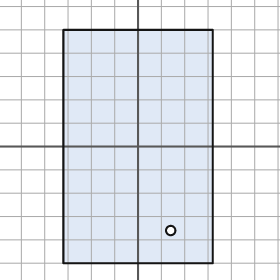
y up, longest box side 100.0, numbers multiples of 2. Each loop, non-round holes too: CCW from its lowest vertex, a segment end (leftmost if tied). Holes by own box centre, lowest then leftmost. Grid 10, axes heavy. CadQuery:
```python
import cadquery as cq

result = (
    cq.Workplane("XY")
    .moveTo(-32.0, -50.0)
    .lineTo(32.0, -50.0)
    .lineTo(32.0, 50.0)
    .lineTo(-32.0, 50.0)
    .close()
    .moveTo(14.0, -36.0)
    .circle(2.0)
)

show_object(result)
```